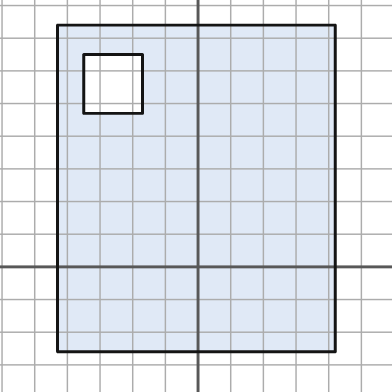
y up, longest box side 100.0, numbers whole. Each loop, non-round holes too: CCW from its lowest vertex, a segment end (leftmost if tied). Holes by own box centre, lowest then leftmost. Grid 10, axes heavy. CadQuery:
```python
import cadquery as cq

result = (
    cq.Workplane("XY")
    .moveTo(-43.0, -26.0)
    .lineTo(42.0, -26.0)
    .lineTo(42.0, 74.0)
    .lineTo(-43.0, 74.0)
    .close()
    .moveTo(-35.0, 47.0)
    .lineTo(-17.0, 47.0)
    .lineTo(-17.0, 65.0)
    .lineTo(-35.0, 65.0)
    .close()
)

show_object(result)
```